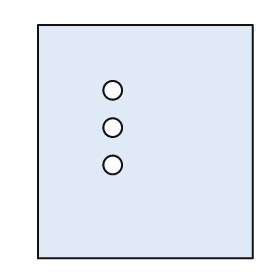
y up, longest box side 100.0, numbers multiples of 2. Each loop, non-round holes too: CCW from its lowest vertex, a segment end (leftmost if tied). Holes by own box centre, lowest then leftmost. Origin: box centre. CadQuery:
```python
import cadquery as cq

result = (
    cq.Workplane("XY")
    .moveTo(-46.0, -50.0)
    .lineTo(46.0, -50.0)
    .lineTo(46.0, 50.0)
    .lineTo(-46.0, 50.0)
    .close()
    .moveTo(-14.0, -10.0)
    .circle(4.0)
    .moveTo(-14.0, 6.0)
    .circle(4.0)
    .moveTo(-14.0, 22.0)
    .circle(4.0)
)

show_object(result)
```